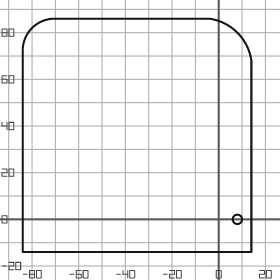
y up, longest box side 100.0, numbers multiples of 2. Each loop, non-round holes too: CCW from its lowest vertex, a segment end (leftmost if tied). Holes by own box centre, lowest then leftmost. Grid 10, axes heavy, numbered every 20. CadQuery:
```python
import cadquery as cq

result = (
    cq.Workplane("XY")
    .moveTo(-84.0, -14.0)
    .lineTo(14.0, -14.0)
    .lineTo(14.0, 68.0)
    .threePointArc((8.0, 80.0), (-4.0, 86.0))
    .lineTo(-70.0, 86.0)
    .threePointArc((-80.0, 82.0), (-84.0, 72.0))
    .close()
    .moveTo(8.0, 0.0)
    .circle(2.0)
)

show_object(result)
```